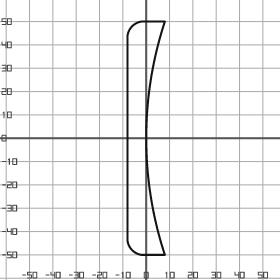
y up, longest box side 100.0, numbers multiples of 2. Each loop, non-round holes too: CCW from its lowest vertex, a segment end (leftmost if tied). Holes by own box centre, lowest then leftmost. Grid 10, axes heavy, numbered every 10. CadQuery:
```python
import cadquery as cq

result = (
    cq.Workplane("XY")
    .moveTo(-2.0, -50.0)
    .lineTo(8.0, -50.0)
    .threePointArc((0.0, 0.0), (8.0, 50.0))
    .lineTo(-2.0, 50.0)
    .threePointArc((-6.0, 48.0), (-8.0, 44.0))
    .lineTo(-8.0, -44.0)
    .threePointArc((-6.0, -48.0), (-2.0, -50.0))
    .close()
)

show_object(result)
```